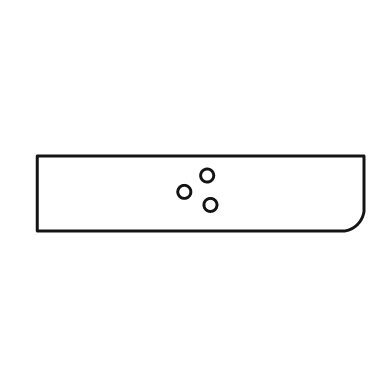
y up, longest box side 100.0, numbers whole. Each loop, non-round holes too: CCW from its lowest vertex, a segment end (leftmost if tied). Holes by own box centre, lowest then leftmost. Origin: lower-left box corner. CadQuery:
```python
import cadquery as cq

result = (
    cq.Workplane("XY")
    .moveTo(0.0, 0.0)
    .lineTo(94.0, 0.0)
    .threePointArc((98.0, 2.0), (100.0, 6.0))
    .lineTo(100.0, 23.0)
    .lineTo(0.0, 23.0)
    .close()
    .moveTo(53.0, 8.0)
    .circle(2.0)
    .moveTo(45.0, 12.0)
    .circle(2.0)
    .moveTo(52.0, 17.0)
    .circle(2.0)
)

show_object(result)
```